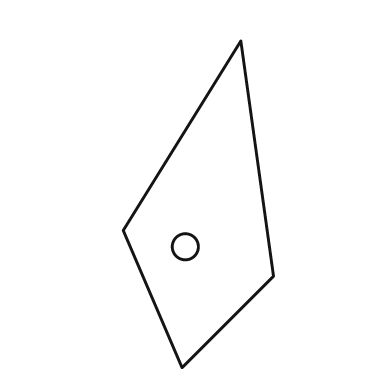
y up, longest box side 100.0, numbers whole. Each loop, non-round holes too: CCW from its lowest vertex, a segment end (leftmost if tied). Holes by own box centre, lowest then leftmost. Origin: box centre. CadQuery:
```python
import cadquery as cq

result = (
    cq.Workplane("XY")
    .moveTo(-5.0, -50.0)
    .lineTo(23.0, -22.0)
    .lineTo(13.0, 50.0)
    .lineTo(-23.0, -8.0)
    .close()
    .moveTo(-4.0, -13.0)
    .circle(4.0)
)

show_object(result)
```